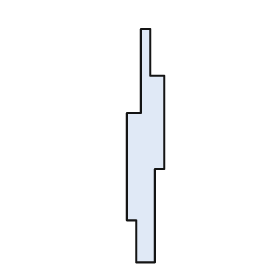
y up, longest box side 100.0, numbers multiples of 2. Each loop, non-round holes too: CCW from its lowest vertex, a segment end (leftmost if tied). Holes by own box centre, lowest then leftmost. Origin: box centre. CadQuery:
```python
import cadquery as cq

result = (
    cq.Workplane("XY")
    .moveTo(-4.0, -50.0)
    .lineTo(4.0, -50.0)
    .lineTo(4.0, -10.0)
    .lineTo(8.0, -10.0)
    .lineTo(8.0, 30.0)
    .lineTo(2.0, 30.0)
    .lineTo(2.0, 50.0)
    .lineTo(-2.0, 50.0)
    .lineTo(-2.0, 14.0)
    .lineTo(-8.0, 14.0)
    .lineTo(-8.0, -32.0)
    .lineTo(-4.0, -32.0)
    .close()
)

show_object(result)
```